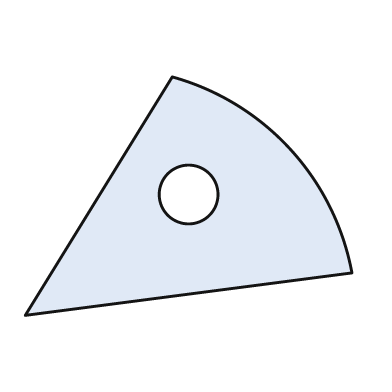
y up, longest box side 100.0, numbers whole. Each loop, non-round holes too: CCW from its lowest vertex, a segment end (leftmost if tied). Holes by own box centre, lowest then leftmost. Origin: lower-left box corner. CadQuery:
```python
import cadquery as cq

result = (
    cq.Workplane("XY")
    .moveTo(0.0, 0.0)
    .lineTo(100.0, 13.0)
    .threePointArc((81.0, 51.0), (45.0, 73.0))
    .close()
    .moveTo(50.0, 37.0)
    .circle(9.0)
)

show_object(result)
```